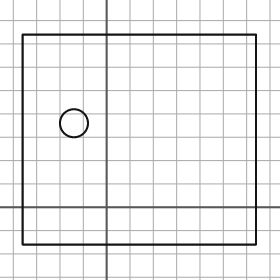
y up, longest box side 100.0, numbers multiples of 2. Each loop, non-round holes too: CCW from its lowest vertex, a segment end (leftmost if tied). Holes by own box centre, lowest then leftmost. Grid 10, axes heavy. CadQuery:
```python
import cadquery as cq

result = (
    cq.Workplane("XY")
    .moveTo(-36.0, -16.0)
    .lineTo(64.0, -16.0)
    .lineTo(64.0, 74.0)
    .lineTo(-36.0, 74.0)
    .close()
    .moveTo(-14.0, 36.0)
    .circle(6.0)
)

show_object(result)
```